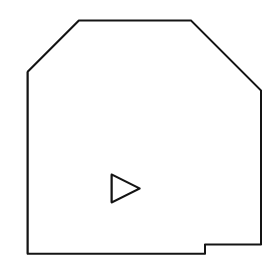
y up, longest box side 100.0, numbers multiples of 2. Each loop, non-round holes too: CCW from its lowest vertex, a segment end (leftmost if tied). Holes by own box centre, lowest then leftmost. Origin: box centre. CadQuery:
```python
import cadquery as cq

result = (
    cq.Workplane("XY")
    .moveTo(-50.0, -50.0)
    .lineTo(26.0, -50.0)
    .lineTo(26.0, -46.0)
    .lineTo(50.0, -46.0)
    .lineTo(50.0, 20.0)
    .lineTo(20.0, 50.0)
    .lineTo(-28.0, 50.0)
    .lineTo(-50.0, 28.0)
    .close()
    .moveTo(-14.0, -28.0)
    .lineTo(-2.0, -22.0)
    .lineTo(-14.0, -16.0)
    .close()
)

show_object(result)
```